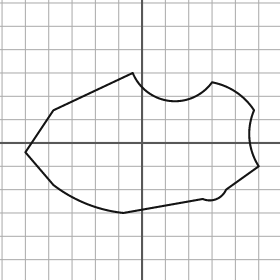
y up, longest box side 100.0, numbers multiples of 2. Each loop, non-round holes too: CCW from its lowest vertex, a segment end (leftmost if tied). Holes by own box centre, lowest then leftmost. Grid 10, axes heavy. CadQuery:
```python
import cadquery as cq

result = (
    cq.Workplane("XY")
    .moveTo(-8.0, -30.0)
    .lineTo(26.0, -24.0)
    .threePointArc((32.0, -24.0), (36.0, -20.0))
    .lineTo(50.0, -10.0)
    .threePointArc((46.0, 2.0), (48.0, 14.0))
    .threePointArc((40.0, 22.0), (30.0, 26.0))
    .threePointArc((12.0, 18.0), (-4.0, 30.0))
    .lineTo(-38.0, 14.0)
    .lineTo(-50.0, -4.0)
    .lineTo(-38.0, -18.0)
    .threePointArc((-24.0, -26.0), (-8.0, -30.0))
    .close()
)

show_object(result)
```